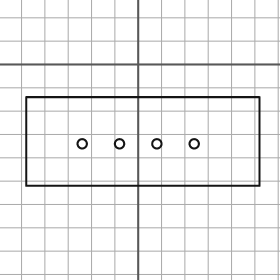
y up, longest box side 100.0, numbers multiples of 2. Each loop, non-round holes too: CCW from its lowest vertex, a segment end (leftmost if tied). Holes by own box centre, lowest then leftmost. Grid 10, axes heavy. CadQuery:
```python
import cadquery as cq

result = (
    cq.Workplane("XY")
    .moveTo(-48.0, -52.0)
    .lineTo(52.0, -52.0)
    .lineTo(52.0, -14.0)
    .lineTo(-48.0, -14.0)
    .close()
    .moveTo(-24.0, -34.0)
    .circle(2.0)
    .moveTo(-8.0, -34.0)
    .circle(2.0)
    .moveTo(8.0, -34.0)
    .circle(2.0)
    .moveTo(24.0, -34.0)
    .circle(2.0)
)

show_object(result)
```